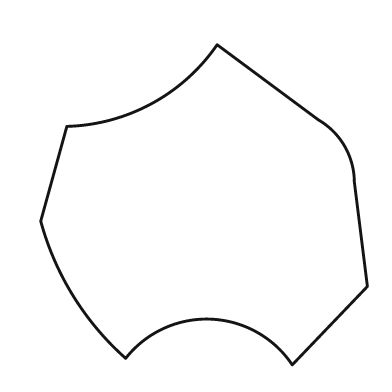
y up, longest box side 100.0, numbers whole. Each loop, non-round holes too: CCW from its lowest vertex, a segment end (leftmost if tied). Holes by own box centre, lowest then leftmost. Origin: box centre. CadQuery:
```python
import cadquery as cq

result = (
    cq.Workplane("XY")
    .moveTo(27.0, -49.0)
    .lineTo(50.0, -25.0)
    .lineTo(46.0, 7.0)
    .threePointArc((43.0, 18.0), (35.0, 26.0))
    .lineTo(4.0, 49.0)
    .threePointArc((-16.0, 31.0), (-42.0, 24.0))
    .lineTo(-50.0, -5.0)
    .threePointArc((-40.0, -28.0), (-24.0, -47.0))
    .threePointArc((2.0, -35.0), (27.0, -49.0))
    .close()
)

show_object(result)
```